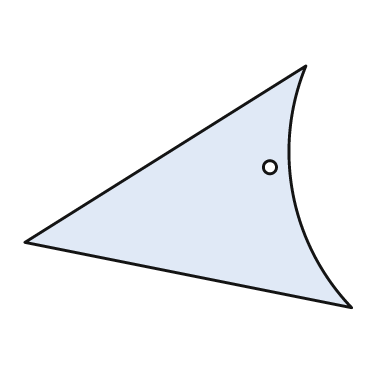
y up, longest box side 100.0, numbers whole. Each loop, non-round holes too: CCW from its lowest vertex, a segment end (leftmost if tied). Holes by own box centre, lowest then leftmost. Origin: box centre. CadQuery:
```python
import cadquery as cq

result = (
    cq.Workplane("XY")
    .moveTo(50.0, -37.0)
    .threePointArc((32.0, -2.0), (36.0, 37.0))
    .lineTo(-50.0, -17.0)
    .close()
    .moveTo(25.0, 6.0)
    .circle(2.0)
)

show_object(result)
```